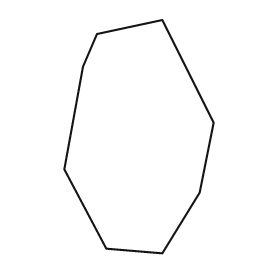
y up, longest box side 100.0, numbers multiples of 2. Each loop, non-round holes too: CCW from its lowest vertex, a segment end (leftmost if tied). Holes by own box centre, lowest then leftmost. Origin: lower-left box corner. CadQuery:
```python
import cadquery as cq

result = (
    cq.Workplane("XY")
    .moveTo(42.0, 0.0)
    .lineTo(58.0, 26.0)
    .lineTo(64.0, 56.0)
    .lineTo(42.0, 100.0)
    .lineTo(14.0, 94.0)
    .lineTo(8.0, 80.0)
    .lineTo(0.0, 36.0)
    .lineTo(18.0, 2.0)
    .close()
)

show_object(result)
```